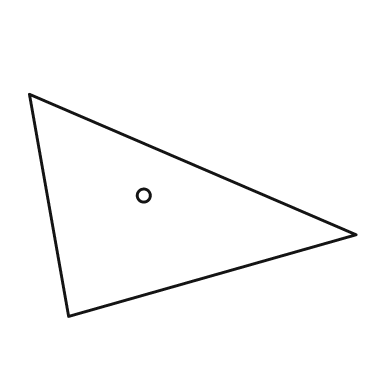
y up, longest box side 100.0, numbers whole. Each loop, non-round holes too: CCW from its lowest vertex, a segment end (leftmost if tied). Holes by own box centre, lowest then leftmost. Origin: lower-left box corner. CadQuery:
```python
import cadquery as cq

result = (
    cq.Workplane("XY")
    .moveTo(12.0, 0.0)
    .lineTo(100.0, 25.0)
    .lineTo(0.0, 68.0)
    .close()
    .moveTo(35.0, 37.0)
    .circle(2.0)
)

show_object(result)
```